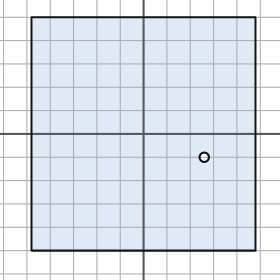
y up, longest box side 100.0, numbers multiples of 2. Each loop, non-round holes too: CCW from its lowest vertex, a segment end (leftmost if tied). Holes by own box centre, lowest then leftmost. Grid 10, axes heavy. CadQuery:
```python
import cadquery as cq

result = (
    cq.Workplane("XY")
    .moveTo(-48.0, -50.0)
    .lineTo(48.0, -50.0)
    .lineTo(48.0, 50.0)
    .lineTo(-48.0, 50.0)
    .close()
    .moveTo(26.0, -10.0)
    .circle(2.0)
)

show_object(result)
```